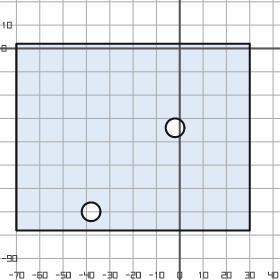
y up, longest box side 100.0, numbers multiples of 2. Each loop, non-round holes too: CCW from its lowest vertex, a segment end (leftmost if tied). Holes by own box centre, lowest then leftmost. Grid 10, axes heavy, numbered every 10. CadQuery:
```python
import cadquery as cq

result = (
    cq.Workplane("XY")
    .moveTo(-70.0, -78.0)
    .lineTo(30.0, -78.0)
    .lineTo(30.0, 2.0)
    .lineTo(-70.0, 2.0)
    .close()
    .moveTo(-38.0, -70.0)
    .circle(4.0)
    .moveTo(-2.0, -34.0)
    .circle(4.0)
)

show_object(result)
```